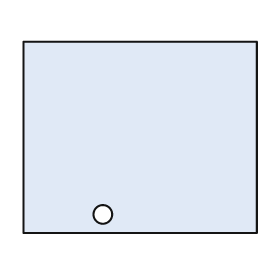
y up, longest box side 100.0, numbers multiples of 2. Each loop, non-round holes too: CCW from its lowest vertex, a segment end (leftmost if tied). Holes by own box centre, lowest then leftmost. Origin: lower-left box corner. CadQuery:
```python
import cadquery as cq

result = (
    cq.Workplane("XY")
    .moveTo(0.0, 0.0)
    .lineTo(100.0, 0.0)
    .lineTo(100.0, 82.0)
    .lineTo(0.0, 82.0)
    .close()
    .moveTo(34.0, 8.0)
    .circle(4.0)
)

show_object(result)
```